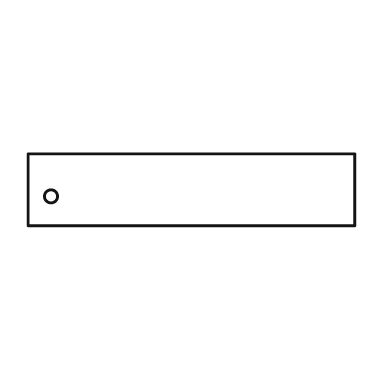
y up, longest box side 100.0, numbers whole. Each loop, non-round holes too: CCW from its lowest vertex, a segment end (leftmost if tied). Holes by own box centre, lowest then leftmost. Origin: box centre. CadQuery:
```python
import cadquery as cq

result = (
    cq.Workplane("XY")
    .moveTo(-50.0, -11.0)
    .lineTo(50.0, -11.0)
    .lineTo(50.0, 11.0)
    .lineTo(-50.0, 11.0)
    .close()
    .moveTo(-43.0, -2.0)
    .circle(2.0)
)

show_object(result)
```